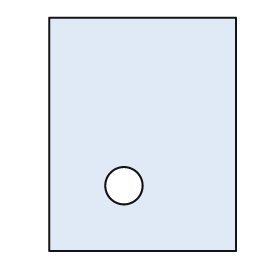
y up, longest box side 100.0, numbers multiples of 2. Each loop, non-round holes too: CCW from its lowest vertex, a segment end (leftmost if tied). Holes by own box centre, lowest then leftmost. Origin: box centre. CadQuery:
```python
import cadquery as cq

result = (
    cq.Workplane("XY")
    .moveTo(-40.0, -50.0)
    .lineTo(40.0, -50.0)
    .lineTo(40.0, 50.0)
    .lineTo(-40.0, 50.0)
    .close()
    .moveTo(-8.0, -22.0)
    .circle(8.0)
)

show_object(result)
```